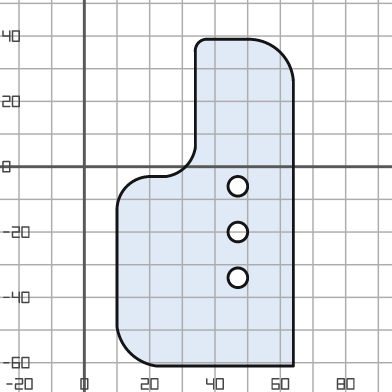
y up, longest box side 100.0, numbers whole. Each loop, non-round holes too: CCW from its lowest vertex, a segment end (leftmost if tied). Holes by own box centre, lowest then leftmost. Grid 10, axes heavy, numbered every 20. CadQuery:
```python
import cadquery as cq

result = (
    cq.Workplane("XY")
    .moveTo(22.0, -61.0)
    .lineTo(64.0, -61.0)
    .lineTo(64.0, 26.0)
    .threePointArc((60.0, 35.0), (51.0, 39.0))
    .lineTo(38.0, 39.0)
    .threePointArc((35.0, 38.0), (34.0, 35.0))
    .lineTo(34.0, 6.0)
    .threePointArc((31.0, 0.0), (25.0, -3.0))
    .lineTo(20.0, -3.0)
    .threePointArc((13.0, -6.0), (10.0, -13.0))
    .lineTo(10.0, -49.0)
    .threePointArc((14.0, -57.0), (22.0, -61.0))
    .close()
    .moveTo(47.0, -34.0)
    .circle(3.0)
    .moveTo(47.0, -20.0)
    .circle(3.0)
    .moveTo(47.0, -6.0)
    .circle(3.0)
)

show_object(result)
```